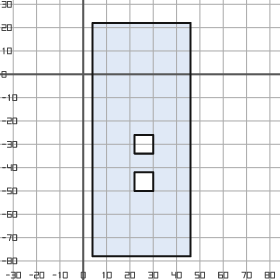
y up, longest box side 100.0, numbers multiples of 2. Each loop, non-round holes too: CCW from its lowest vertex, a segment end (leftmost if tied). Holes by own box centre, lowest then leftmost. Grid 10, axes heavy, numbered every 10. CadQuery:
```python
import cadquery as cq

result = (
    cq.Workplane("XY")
    .moveTo(4.0, -78.0)
    .lineTo(46.0, -78.0)
    .lineTo(46.0, 22.0)
    .lineTo(4.0, 22.0)
    .close()
    .moveTo(22.0, -50.0)
    .lineTo(30.0, -50.0)
    .lineTo(30.0, -42.0)
    .lineTo(22.0, -42.0)
    .close()
    .moveTo(22.0, -34.0)
    .lineTo(30.0, -34.0)
    .lineTo(30.0, -26.0)
    .lineTo(22.0, -26.0)
    .close()
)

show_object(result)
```